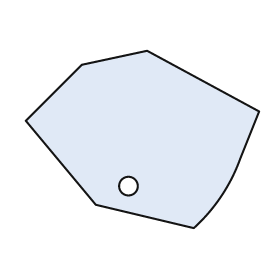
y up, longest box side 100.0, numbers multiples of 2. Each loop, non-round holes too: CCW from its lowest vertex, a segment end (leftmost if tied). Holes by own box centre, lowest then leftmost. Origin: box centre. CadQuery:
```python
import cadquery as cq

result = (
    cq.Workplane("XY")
    .moveTo(22.0, -38.0)
    .threePointArc((34.0, -24.0), (42.0, -8.0))
    .lineTo(50.0, 12.0)
    .lineTo(2.0, 38.0)
    .lineTo(-26.0, 32.0)
    .lineTo(-50.0, 8.0)
    .lineTo(-20.0, -28.0)
    .close()
    .moveTo(-6.0, -20.0)
    .circle(4.0)
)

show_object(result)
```